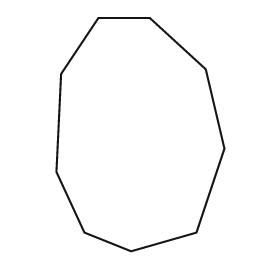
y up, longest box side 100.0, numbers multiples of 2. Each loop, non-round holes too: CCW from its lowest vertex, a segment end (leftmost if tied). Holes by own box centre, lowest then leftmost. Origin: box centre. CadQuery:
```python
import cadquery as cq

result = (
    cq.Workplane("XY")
    .moveTo(-4.0, -50.0)
    .lineTo(24.0, -42.0)
    .lineTo(36.0, -6.0)
    .lineTo(28.0, 28.0)
    .lineTo(4.0, 50.0)
    .lineTo(-18.0, 50.0)
    .lineTo(-34.0, 26.0)
    .lineTo(-36.0, -16.0)
    .lineTo(-24.0, -42.0)
    .close()
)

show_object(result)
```